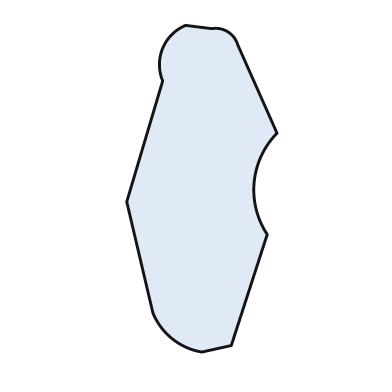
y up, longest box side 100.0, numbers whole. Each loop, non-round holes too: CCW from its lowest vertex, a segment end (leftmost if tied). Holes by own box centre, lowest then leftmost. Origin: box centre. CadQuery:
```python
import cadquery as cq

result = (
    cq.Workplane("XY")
    .moveTo(0.0, -50.0)
    .lineTo(9.0, -48.0)
    .lineTo(20.0, -14.0)
    .threePointArc((16.0, 2.0), (23.0, 17.0))
    .lineTo(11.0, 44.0)
    .threePointArc((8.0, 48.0), (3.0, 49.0))
    .lineTo(-5.0, 50.0)
    .threePointArc((-12.0, 43.0), (-12.0, 33.0))
    .lineTo(-23.0, -4.0)
    .lineTo(-15.0, -38.0)
    .threePointArc((-9.0, -46.0), (0.0, -50.0))
    .close()
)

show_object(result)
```